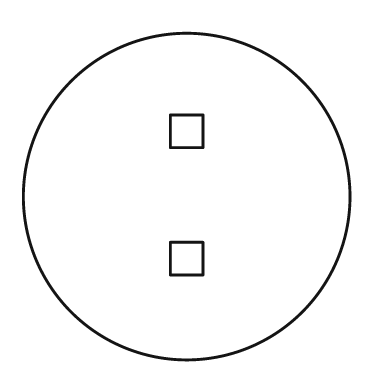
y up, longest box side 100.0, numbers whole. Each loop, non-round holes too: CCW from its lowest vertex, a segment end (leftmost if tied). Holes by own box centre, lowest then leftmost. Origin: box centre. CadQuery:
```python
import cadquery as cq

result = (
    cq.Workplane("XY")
    .moveTo(0.0, 0.0)
    .circle(50.0)
    .moveTo(-5.0, -24.0)
    .lineTo(5.0, -24.0)
    .lineTo(5.0, -14.0)
    .lineTo(-5.0, -14.0)
    .close()
    .moveTo(-5.0, 15.0)
    .lineTo(5.0, 15.0)
    .lineTo(5.0, 25.0)
    .lineTo(-5.0, 25.0)
    .close()
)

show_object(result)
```